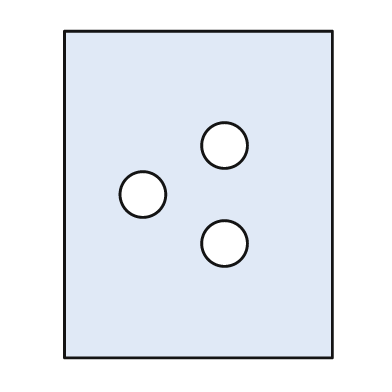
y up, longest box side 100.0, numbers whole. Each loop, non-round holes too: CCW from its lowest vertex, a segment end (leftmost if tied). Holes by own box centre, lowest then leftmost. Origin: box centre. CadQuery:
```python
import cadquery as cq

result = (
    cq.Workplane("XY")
    .moveTo(-41.0, -50.0)
    .lineTo(41.0, -50.0)
    .lineTo(41.0, 50.0)
    .lineTo(-41.0, 50.0)
    .close()
    .moveTo(8.0, -15.0)
    .circle(7.0)
    .moveTo(-17.0, 0.0)
    .circle(7.0)
    .moveTo(8.0, 15.0)
    .circle(7.0)
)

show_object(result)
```